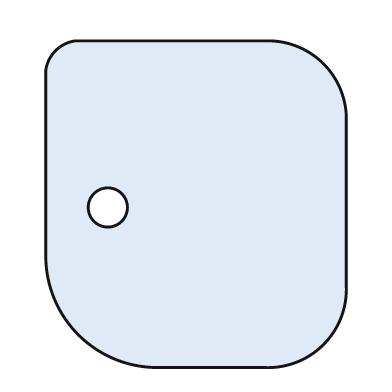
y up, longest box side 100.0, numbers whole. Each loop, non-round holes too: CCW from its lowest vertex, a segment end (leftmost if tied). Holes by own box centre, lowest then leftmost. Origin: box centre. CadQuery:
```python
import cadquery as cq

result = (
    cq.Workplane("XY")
    .moveTo(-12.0, -50.0)
    .lineTo(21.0, -50.0)
    .threePointArc((39.0, -43.0), (46.0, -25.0))
    .lineTo(46.0, 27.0)
    .threePointArc((39.0, 43.0), (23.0, 50.0))
    .lineTo(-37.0, 50.0)
    .threePointArc((-43.0, 47.0), (-46.0, 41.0))
    .lineTo(-46.0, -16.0)
    .threePointArc((-36.0, -40.0), (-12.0, -50.0))
    .close()
    .moveTo(-27.0, -1.0)
    .circle(6.0)
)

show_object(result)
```